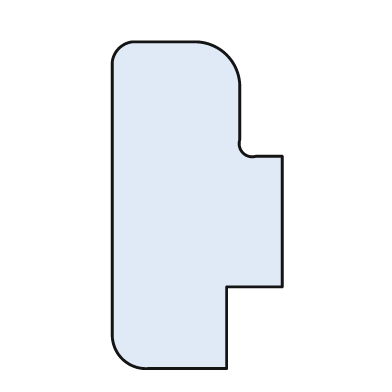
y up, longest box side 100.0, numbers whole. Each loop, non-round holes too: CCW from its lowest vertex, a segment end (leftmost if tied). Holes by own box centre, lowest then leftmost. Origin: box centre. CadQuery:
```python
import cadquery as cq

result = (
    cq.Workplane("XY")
    .moveTo(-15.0, -50.0)
    .lineTo(9.0, -50.0)
    .lineTo(9.0, -25.0)
    .lineTo(26.0, -25.0)
    .lineTo(26.0, 15.0)
    .lineTo(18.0, 15.0)
    .threePointArc((14.0, 16.0), (13.0, 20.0))
    .lineTo(13.0, 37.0)
    .threePointArc((9.0, 46.0), (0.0, 50.0))
    .lineTo(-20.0, 50.0)
    .threePointArc((-24.0, 48.0), (-26.0, 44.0))
    .lineTo(-26.0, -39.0)
    .threePointArc((-23.0, -47.0), (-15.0, -50.0))
    .close()
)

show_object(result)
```